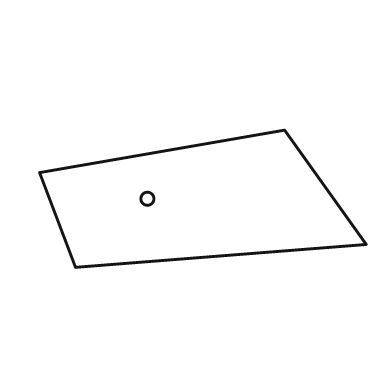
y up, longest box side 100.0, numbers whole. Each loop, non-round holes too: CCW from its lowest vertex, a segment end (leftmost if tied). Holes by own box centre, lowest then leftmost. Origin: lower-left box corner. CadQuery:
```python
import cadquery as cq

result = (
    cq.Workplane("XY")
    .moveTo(11.0, 0.0)
    .lineTo(100.0, 7.0)
    .lineTo(75.0, 42.0)
    .lineTo(0.0, 29.0)
    .close()
    .moveTo(33.0, 21.0)
    .circle(2.0)
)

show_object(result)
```